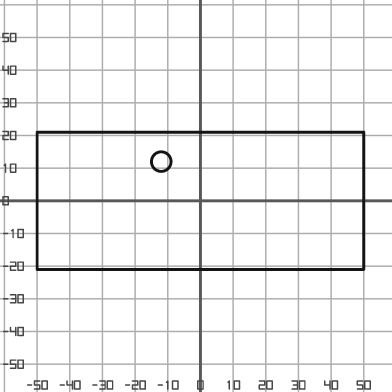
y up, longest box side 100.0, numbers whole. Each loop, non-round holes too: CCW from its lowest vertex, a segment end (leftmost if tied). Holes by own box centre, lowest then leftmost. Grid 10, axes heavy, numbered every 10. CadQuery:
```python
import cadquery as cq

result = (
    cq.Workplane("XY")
    .moveTo(-50.0, -21.0)
    .lineTo(50.0, -21.0)
    .lineTo(50.0, 21.0)
    .lineTo(-50.0, 21.0)
    .close()
    .moveTo(-12.0, 12.0)
    .circle(3.0)
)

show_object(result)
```